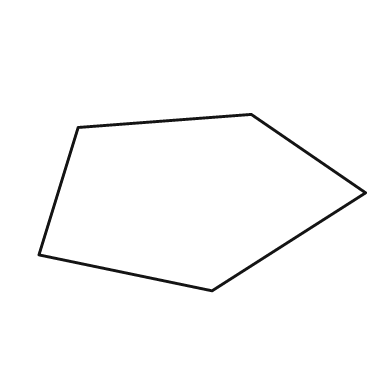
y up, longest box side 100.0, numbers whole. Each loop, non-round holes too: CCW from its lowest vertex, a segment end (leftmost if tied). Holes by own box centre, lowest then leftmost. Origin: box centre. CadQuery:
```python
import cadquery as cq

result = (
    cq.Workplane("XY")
    .moveTo(3.0, -27.0)
    .lineTo(50.0, 3.0)
    .lineTo(15.0, 27.0)
    .lineTo(-38.0, 23.0)
    .lineTo(-50.0, -16.0)
    .close()
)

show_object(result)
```